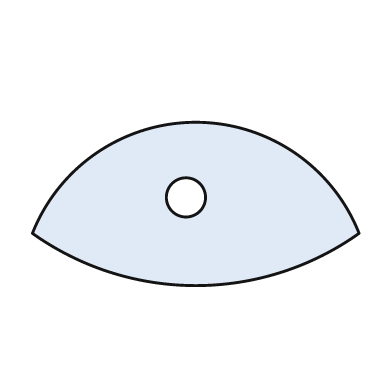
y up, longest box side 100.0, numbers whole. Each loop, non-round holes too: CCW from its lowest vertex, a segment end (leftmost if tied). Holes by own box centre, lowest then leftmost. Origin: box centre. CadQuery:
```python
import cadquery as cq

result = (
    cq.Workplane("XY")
    .moveTo(-50.0, -9.0)
    .threePointArc((0.0, -25.0), (50.0, -9.0))
    .threePointArc((0.0, 25.0), (-50.0, -9.0))
    .close()
    .moveTo(-3.0, 2.0)
    .circle(6.0)
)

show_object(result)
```